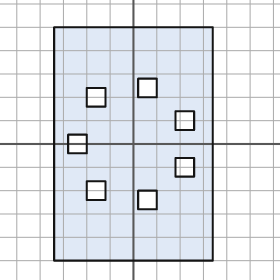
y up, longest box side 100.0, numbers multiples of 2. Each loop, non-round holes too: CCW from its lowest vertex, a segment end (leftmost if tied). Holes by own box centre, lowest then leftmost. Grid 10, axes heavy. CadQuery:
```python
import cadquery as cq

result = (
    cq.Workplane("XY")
    .moveTo(-34.0, -50.0)
    .lineTo(34.0, -50.0)
    .lineTo(34.0, 50.0)
    .lineTo(-34.0, 50.0)
    .close()
    .moveTo(2.0, -28.0)
    .lineTo(10.0, -28.0)
    .lineTo(10.0, -20.0)
    .lineTo(2.0, -20.0)
    .close()
    .moveTo(-20.0, -24.0)
    .lineTo(-12.0, -24.0)
    .lineTo(-12.0, -16.0)
    .lineTo(-20.0, -16.0)
    .close()
    .moveTo(18.0, -14.0)
    .lineTo(26.0, -14.0)
    .lineTo(26.0, -6.0)
    .lineTo(18.0, -6.0)
    .close()
    .moveTo(-28.0, -4.0)
    .lineTo(-20.0, -4.0)
    .lineTo(-20.0, 4.0)
    .lineTo(-28.0, 4.0)
    .close()
    .moveTo(18.0, 6.0)
    .lineTo(26.0, 6.0)
    .lineTo(26.0, 14.0)
    .lineTo(18.0, 14.0)
    .close()
    .moveTo(-20.0, 16.0)
    .lineTo(-12.0, 16.0)
    .lineTo(-12.0, 24.0)
    .lineTo(-20.0, 24.0)
    .close()
    .moveTo(2.0, 20.0)
    .lineTo(10.0, 20.0)
    .lineTo(10.0, 28.0)
    .lineTo(2.0, 28.0)
    .close()
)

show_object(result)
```